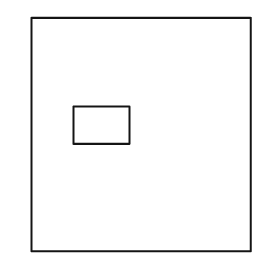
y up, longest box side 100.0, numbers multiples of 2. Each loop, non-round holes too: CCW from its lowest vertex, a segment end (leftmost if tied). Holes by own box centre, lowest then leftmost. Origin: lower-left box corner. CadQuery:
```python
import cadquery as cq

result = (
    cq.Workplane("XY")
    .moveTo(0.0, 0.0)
    .lineTo(94.0, 0.0)
    .lineTo(94.0, 100.0)
    .lineTo(0.0, 100.0)
    .close()
    .moveTo(18.0, 46.0)
    .lineTo(42.0, 46.0)
    .lineTo(42.0, 62.0)
    .lineTo(18.0, 62.0)
    .close()
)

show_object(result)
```